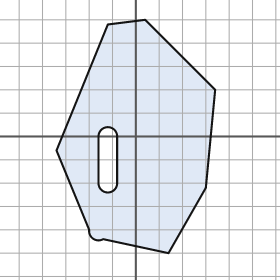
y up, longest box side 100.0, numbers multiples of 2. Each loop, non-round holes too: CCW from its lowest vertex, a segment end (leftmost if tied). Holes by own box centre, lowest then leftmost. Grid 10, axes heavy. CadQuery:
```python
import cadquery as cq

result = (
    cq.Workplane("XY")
    .moveTo(14.0, -50.0)
    .lineTo(30.0, -22.0)
    .lineTo(34.0, 20.0)
    .lineTo(4.0, 50.0)
    .lineTo(-12.0, 48.0)
    .lineTo(-34.0, -6.0)
    .lineTo(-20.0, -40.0)
    .threePointArc((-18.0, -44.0), (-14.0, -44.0))
    .close()
    .moveTo(-16.0, -20.0)
    .threePointArc((-12.0, -24.0), (-8.0, -20.0))
    .lineTo(-8.0, 0.0)
    .threePointArc((-12.0, 4.0), (-16.0, 0.0))
    .close()
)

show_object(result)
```